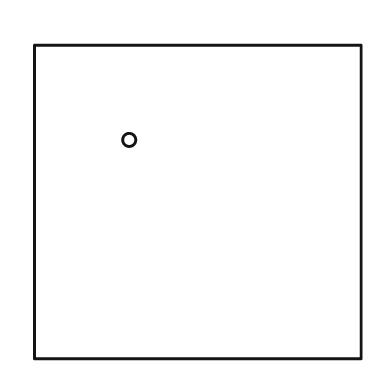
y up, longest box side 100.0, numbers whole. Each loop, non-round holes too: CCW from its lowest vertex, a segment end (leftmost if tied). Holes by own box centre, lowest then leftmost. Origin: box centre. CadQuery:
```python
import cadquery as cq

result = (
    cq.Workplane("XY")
    .moveTo(-50.0, -48.0)
    .lineTo(50.0, -48.0)
    .lineTo(50.0, 48.0)
    .lineTo(-50.0, 48.0)
    .close()
    .moveTo(-21.0, 19.0)
    .circle(2.0)
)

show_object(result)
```